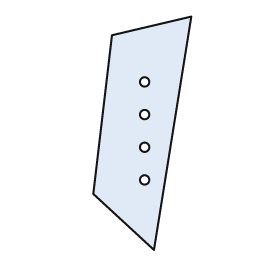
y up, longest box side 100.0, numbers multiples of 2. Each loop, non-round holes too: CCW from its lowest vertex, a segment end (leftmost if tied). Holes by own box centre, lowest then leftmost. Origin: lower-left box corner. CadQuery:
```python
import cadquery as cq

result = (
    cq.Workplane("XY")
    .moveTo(26.0, 0.0)
    .lineTo(42.0, 100.0)
    .lineTo(8.0, 92.0)
    .lineTo(0.0, 24.0)
    .close()
    .moveTo(22.0, 30.0)
    .circle(2.0)
    .moveTo(22.0, 44.0)
    .circle(2.0)
    .moveTo(22.0, 58.0)
    .circle(2.0)
    .moveTo(22.0, 72.0)
    .circle(2.0)
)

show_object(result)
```